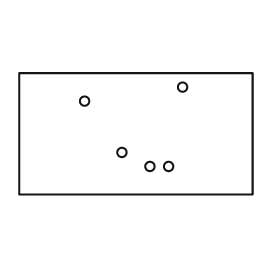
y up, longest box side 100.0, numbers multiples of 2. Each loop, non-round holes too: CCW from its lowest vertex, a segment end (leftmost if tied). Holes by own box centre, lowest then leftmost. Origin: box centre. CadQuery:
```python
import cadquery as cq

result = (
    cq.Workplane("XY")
    .moveTo(-50.0, -26.0)
    .lineTo(50.0, -26.0)
    .lineTo(50.0, 26.0)
    .lineTo(-50.0, 26.0)
    .close()
    .moveTo(6.0, -14.0)
    .circle(2.0)
    .moveTo(14.0, -14.0)
    .circle(2.0)
    .moveTo(-6.0, -8.0)
    .circle(2.0)
    .moveTo(-22.0, 14.0)
    .circle(2.0)
    .moveTo(20.0, 20.0)
    .circle(2.0)
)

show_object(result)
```